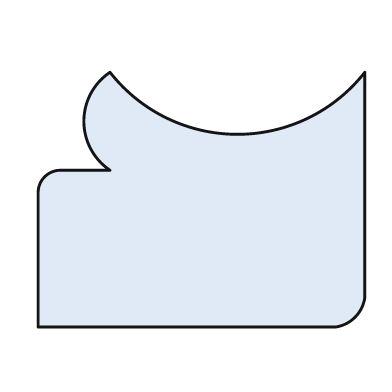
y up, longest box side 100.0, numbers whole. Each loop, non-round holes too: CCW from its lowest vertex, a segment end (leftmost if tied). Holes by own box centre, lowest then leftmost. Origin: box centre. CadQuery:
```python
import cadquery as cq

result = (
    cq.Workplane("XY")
    .moveTo(-50.0, -39.0)
    .lineTo(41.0, -39.0)
    .threePointArc((47.0, -36.0), (50.0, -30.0))
    .lineTo(50.0, 39.0)
    .threePointArc((11.0, 20.0), (-28.0, 39.0))
    .threePointArc((-36.0, 24.0), (-28.0, 9.0))
    .lineTo(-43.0, 9.0)
    .threePointArc((-48.0, 7.0), (-50.0, 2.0))
    .close()
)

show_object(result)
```